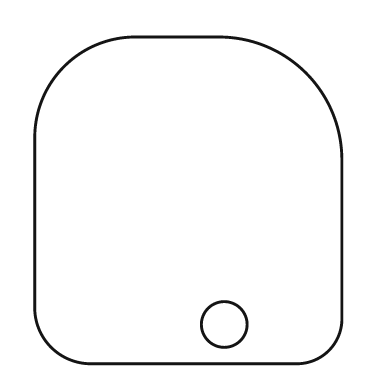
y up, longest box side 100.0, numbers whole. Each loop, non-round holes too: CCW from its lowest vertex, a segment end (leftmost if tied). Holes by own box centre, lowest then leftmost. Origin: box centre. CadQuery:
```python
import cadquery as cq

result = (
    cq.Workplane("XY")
    .moveTo(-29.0, -50.0)
    .lineTo(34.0, -50.0)
    .threePointArc((43.0, -46.0), (47.0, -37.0))
    .lineTo(47.0, 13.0)
    .threePointArc((36.0, 39.0), (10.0, 50.0))
    .lineTo(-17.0, 50.0)
    .threePointArc((-38.0, 41.0), (-47.0, 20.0))
    .lineTo(-47.0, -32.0)
    .threePointArc((-42.0, -45.0), (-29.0, -50.0))
    .close()
    .moveTo(11.0, -38.0)
    .circle(7.0)
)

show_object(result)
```